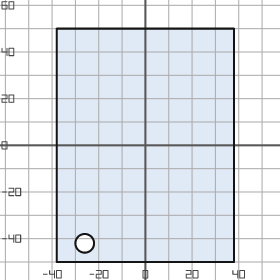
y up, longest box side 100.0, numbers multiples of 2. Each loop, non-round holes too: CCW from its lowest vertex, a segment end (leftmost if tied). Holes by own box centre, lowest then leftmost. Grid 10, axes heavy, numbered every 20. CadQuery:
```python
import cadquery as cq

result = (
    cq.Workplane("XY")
    .moveTo(-38.0, -50.0)
    .lineTo(38.0, -50.0)
    .lineTo(38.0, 50.0)
    .lineTo(-38.0, 50.0)
    .close()
    .moveTo(-26.0, -42.0)
    .circle(4.0)
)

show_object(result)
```